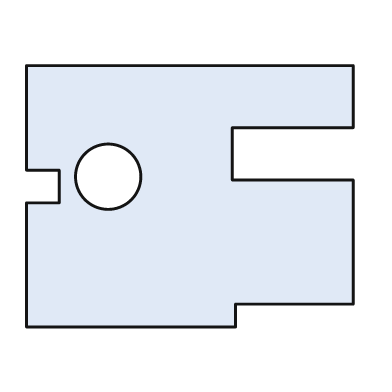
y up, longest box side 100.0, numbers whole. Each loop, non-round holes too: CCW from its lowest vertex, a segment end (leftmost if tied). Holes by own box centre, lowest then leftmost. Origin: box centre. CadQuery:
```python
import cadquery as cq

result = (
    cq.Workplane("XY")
    .moveTo(-50.0, -40.0)
    .lineTo(14.0, -40.0)
    .lineTo(14.0, -33.0)
    .lineTo(50.0, -33.0)
    .lineTo(50.0, 5.0)
    .lineTo(13.0, 5.0)
    .lineTo(13.0, 21.0)
    .lineTo(50.0, 21.0)
    .lineTo(50.0, 40.0)
    .lineTo(-50.0, 40.0)
    .lineTo(-50.0, 8.0)
    .lineTo(-40.0, 8.0)
    .lineTo(-40.0, -2.0)
    .lineTo(-50.0, -2.0)
    .close()
    .moveTo(-25.0, 6.0)
    .circle(10.0)
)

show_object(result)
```